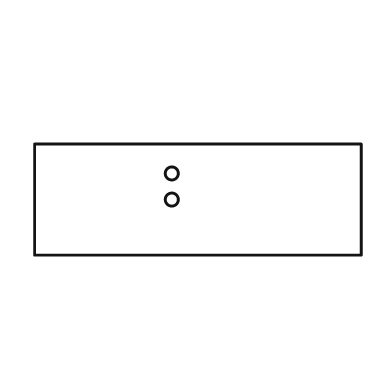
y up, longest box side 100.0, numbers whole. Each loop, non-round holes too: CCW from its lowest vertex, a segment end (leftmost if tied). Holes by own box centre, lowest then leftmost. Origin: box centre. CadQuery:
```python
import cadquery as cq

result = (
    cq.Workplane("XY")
    .moveTo(-50.0, -17.0)
    .lineTo(50.0, -17.0)
    .lineTo(50.0, 17.0)
    .lineTo(-50.0, 17.0)
    .close()
    .moveTo(-8.0, 0.0)
    .circle(2.0)
    .moveTo(-8.0, 8.0)
    .circle(2.0)
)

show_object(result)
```